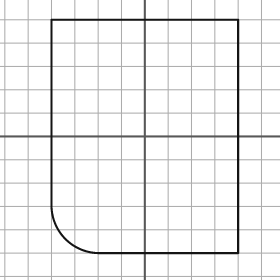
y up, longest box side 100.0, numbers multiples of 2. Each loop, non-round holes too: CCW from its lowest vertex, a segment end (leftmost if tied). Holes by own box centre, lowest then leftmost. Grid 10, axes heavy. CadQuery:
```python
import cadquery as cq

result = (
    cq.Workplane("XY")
    .moveTo(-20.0, -50.0)
    .lineTo(40.0, -50.0)
    .lineTo(40.0, 50.0)
    .lineTo(-40.0, 50.0)
    .lineTo(-40.0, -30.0)
    .threePointArc((-34.0, -44.0), (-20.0, -50.0))
    .close()
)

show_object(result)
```